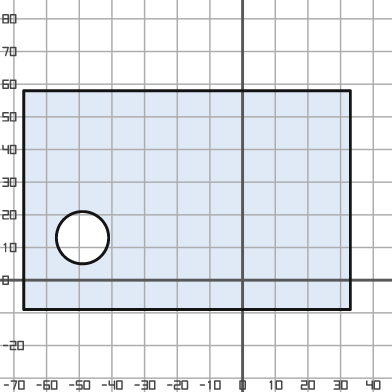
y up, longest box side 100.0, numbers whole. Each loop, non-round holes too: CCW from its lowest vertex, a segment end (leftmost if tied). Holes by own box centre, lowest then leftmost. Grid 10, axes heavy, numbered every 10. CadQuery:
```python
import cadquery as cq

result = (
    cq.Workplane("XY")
    .moveTo(-67.0, -9.0)
    .lineTo(33.0, -9.0)
    .lineTo(33.0, 58.0)
    .lineTo(-67.0, 58.0)
    .close()
    .moveTo(-49.0, 13.0)
    .circle(8.0)
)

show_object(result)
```